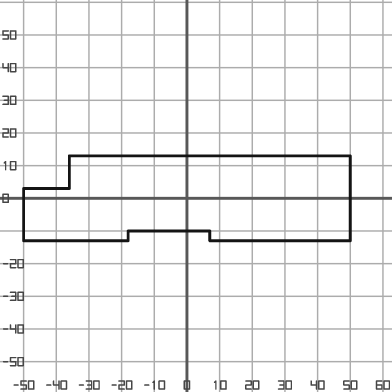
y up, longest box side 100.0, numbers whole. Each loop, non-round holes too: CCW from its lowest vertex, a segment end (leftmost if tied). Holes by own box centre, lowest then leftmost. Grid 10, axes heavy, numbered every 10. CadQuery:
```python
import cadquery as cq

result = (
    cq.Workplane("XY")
    .moveTo(-50.0, -13.0)
    .lineTo(-18.0, -13.0)
    .lineTo(-18.0, -10.0)
    .lineTo(7.0, -10.0)
    .lineTo(7.0, -13.0)
    .lineTo(50.0, -13.0)
    .lineTo(50.0, 13.0)
    .lineTo(-36.0, 13.0)
    .lineTo(-36.0, 3.0)
    .lineTo(-50.0, 3.0)
    .close()
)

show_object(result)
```